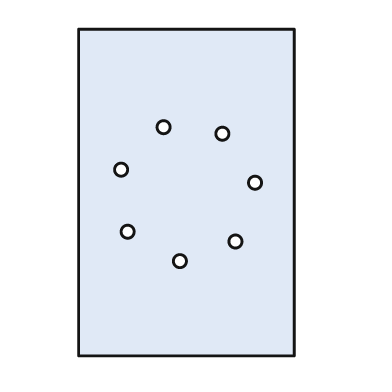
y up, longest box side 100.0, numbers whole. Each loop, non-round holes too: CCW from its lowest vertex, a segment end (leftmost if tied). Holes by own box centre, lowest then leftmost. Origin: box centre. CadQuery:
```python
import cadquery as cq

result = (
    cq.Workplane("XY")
    .moveTo(-33.0, -50.0)
    .lineTo(33.0, -50.0)
    .lineTo(33.0, 50.0)
    .lineTo(-33.0, 50.0)
    .close()
    .moveTo(-2.0, -21.0)
    .circle(2.0)
    .moveTo(15.0, -15.0)
    .circle(2.0)
    .moveTo(-18.0, -12.0)
    .circle(2.0)
    .moveTo(21.0, 3.0)
    .circle(2.0)
    .moveTo(-20.0, 7.0)
    .circle(2.0)
    .moveTo(11.0, 18.0)
    .circle(2.0)
    .moveTo(-7.0, 20.0)
    .circle(2.0)
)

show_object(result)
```